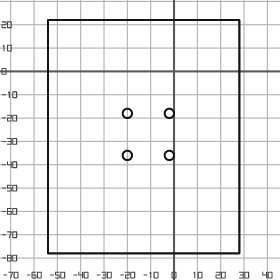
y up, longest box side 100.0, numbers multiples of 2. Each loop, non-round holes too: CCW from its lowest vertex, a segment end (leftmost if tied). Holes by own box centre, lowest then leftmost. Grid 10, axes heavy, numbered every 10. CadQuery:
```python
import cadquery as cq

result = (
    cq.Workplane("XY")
    .moveTo(-54.0, -78.0)
    .lineTo(28.0, -78.0)
    .lineTo(28.0, 22.0)
    .lineTo(-54.0, 22.0)
    .close()
    .moveTo(-20.0, -36.0)
    .circle(2.0)
    .moveTo(-2.0, -36.0)
    .circle(2.0)
    .moveTo(-20.0, -18.0)
    .circle(2.0)
    .moveTo(-2.0, -18.0)
    .circle(2.0)
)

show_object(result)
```